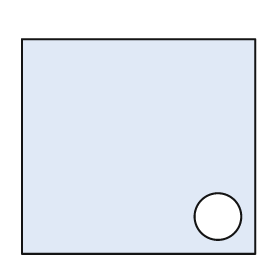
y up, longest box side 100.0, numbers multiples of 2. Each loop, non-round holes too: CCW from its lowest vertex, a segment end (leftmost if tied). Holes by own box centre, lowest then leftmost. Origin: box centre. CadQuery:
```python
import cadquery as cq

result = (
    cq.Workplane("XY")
    .moveTo(-50.0, -46.0)
    .lineTo(50.0, -46.0)
    .lineTo(50.0, 46.0)
    .lineTo(-50.0, 46.0)
    .close()
    .moveTo(34.0, -30.0)
    .circle(10.0)
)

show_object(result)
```